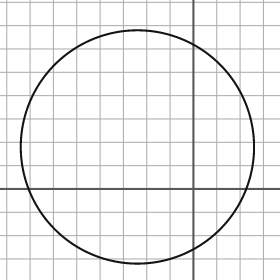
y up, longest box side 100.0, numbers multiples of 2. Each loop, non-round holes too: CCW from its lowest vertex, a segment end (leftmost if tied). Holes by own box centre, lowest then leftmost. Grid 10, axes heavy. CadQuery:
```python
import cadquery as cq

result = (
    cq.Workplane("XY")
    .moveTo(-24.0, 18.0)
    .circle(50.0)
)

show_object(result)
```